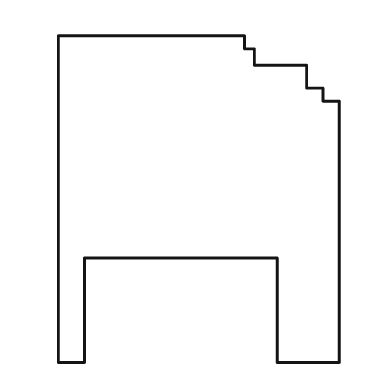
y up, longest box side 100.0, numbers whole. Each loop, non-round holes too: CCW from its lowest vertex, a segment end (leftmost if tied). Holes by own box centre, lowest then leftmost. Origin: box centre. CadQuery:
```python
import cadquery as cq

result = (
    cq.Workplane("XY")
    .moveTo(-43.0, -50.0)
    .lineTo(-35.0, -50.0)
    .lineTo(-35.0, -18.0)
    .lineTo(24.0, -18.0)
    .lineTo(24.0, -50.0)
    .lineTo(43.0, -50.0)
    .lineTo(43.0, 30.0)
    .lineTo(38.0, 30.0)
    .lineTo(38.0, 34.0)
    .lineTo(33.0, 34.0)
    .lineTo(33.0, 41.0)
    .lineTo(17.0, 41.0)
    .lineTo(17.0, 46.0)
    .lineTo(14.0, 46.0)
    .lineTo(14.0, 50.0)
    .lineTo(-43.0, 50.0)
    .close()
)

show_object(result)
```